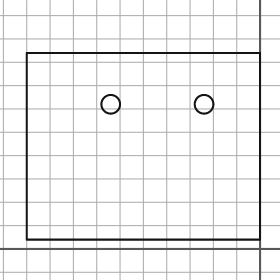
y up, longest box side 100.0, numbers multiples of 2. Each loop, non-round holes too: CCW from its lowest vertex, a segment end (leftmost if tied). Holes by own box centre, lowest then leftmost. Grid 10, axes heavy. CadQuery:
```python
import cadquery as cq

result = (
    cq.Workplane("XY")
    .moveTo(-100.0, 4.0)
    .lineTo(0.0, 4.0)
    .lineTo(0.0, 84.0)
    .lineTo(-100.0, 84.0)
    .close()
    .moveTo(-64.0, 62.0)
    .circle(4.0)
    .moveTo(-24.0, 62.0)
    .circle(4.0)
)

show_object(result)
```